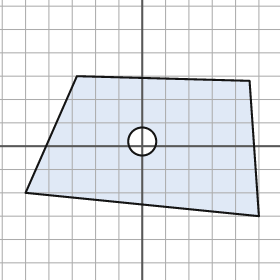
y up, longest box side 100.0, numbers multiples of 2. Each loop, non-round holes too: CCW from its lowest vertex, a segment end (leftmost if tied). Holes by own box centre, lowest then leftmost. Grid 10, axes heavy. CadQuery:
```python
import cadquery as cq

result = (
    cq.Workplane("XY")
    .moveTo(50.0, -30.0)
    .lineTo(46.0, 28.0)
    .lineTo(-28.0, 30.0)
    .lineTo(-50.0, -20.0)
    .close()
    .moveTo(0.0, 2.0)
    .circle(6.0)
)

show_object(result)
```